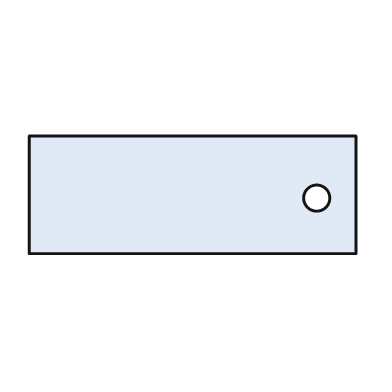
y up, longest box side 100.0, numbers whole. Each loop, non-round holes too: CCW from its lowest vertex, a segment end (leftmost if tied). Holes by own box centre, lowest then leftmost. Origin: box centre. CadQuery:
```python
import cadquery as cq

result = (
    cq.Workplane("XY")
    .moveTo(-50.0, -18.0)
    .lineTo(50.0, -18.0)
    .lineTo(50.0, 18.0)
    .lineTo(-50.0, 18.0)
    .close()
    .moveTo(38.0, -1.0)
    .circle(4.0)
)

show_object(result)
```